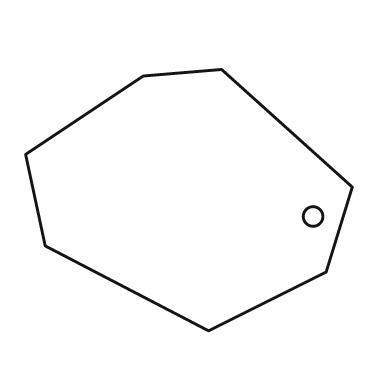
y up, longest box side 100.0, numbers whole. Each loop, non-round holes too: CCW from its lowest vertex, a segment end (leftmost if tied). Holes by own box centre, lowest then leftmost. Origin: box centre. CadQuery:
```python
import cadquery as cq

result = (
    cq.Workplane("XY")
    .moveTo(6.0, -40.0)
    .lineTo(42.0, -22.0)
    .lineTo(50.0, 4.0)
    .lineTo(10.0, 40.0)
    .lineTo(-14.0, 38.0)
    .lineTo(-50.0, 14.0)
    .lineTo(-44.0, -14.0)
    .close()
    .moveTo(38.0, -5.0)
    .circle(3.0)
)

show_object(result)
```